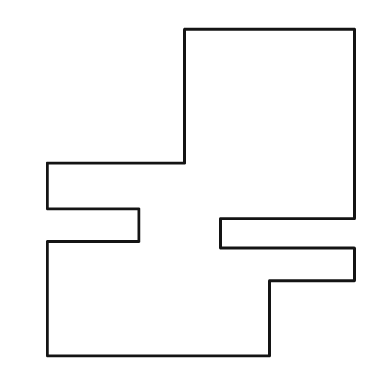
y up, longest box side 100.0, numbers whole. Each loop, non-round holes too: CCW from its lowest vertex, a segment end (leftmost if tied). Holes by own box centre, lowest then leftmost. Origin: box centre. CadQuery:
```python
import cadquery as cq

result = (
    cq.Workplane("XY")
    .moveTo(-47.0, -50.0)
    .lineTo(21.0, -50.0)
    .lineTo(21.0, -27.0)
    .lineTo(47.0, -27.0)
    .lineTo(47.0, -17.0)
    .lineTo(6.0, -17.0)
    .lineTo(6.0, -8.0)
    .lineTo(47.0, -8.0)
    .lineTo(47.0, 50.0)
    .lineTo(-5.0, 50.0)
    .lineTo(-5.0, 9.0)
    .lineTo(-47.0, 9.0)
    .lineTo(-47.0, -5.0)
    .lineTo(-19.0, -5.0)
    .lineTo(-19.0, -15.0)
    .lineTo(-47.0, -15.0)
    .close()
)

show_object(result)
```